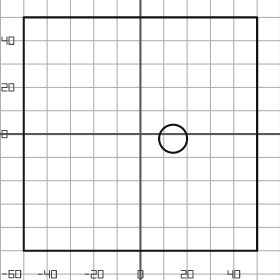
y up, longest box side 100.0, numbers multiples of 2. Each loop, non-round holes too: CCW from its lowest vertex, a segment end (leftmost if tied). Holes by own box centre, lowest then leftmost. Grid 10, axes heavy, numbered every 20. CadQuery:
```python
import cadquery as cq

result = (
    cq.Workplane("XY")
    .moveTo(-50.0, -50.0)
    .lineTo(50.0, -50.0)
    .lineTo(50.0, 50.0)
    .lineTo(-50.0, 50.0)
    .close()
    .moveTo(14.0, -2.0)
    .circle(6.0)
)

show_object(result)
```